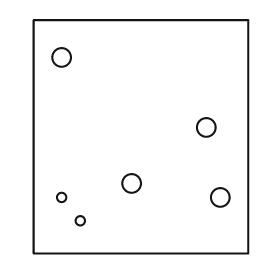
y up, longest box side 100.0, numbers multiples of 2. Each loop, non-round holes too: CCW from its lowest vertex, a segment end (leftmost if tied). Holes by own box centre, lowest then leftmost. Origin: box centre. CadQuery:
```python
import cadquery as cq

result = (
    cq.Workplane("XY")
    .moveTo(-46.0, -50.0)
    .lineTo(46.0, -50.0)
    .lineTo(46.0, 50.0)
    .lineTo(-46.0, 50.0)
    .close()
    .moveTo(-26.0, -36.0)
    .circle(2.0)
    .moveTo(-34.0, -26.0)
    .circle(2.0)
    .moveTo(34.0, -26.0)
    .circle(4.0)
    .moveTo(-4.0, -20.0)
    .circle(4.0)
    .moveTo(28.0, 4.0)
    .circle(4.0)
    .moveTo(-34.0, 34.0)
    .circle(4.0)
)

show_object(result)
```